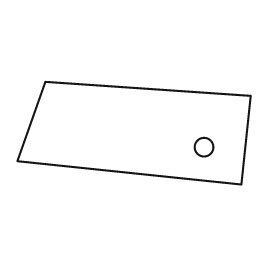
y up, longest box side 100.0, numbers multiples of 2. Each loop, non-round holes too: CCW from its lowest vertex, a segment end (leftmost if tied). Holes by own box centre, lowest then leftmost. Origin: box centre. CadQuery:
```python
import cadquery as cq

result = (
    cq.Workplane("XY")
    .moveTo(46.0, -22.0)
    .lineTo(50.0, 16.0)
    .lineTo(-38.0, 22.0)
    .lineTo(-50.0, -12.0)
    .close()
    .moveTo(30.0, -6.0)
    .circle(4.0)
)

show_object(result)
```